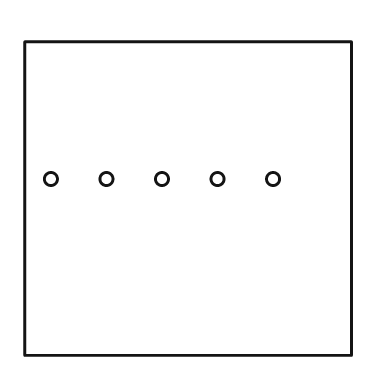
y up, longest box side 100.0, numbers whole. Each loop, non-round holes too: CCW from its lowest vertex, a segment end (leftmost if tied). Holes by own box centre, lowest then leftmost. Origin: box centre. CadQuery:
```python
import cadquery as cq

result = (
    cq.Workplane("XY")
    .moveTo(-50.0, -48.0)
    .lineTo(50.0, -48.0)
    .lineTo(50.0, 48.0)
    .lineTo(-50.0, 48.0)
    .close()
    .moveTo(-42.0, 6.0)
    .circle(2.0)
    .moveTo(-25.0, 6.0)
    .circle(2.0)
    .moveTo(-8.0, 6.0)
    .circle(2.0)
    .moveTo(9.0, 6.0)
    .circle(2.0)
    .moveTo(26.0, 6.0)
    .circle(2.0)
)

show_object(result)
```